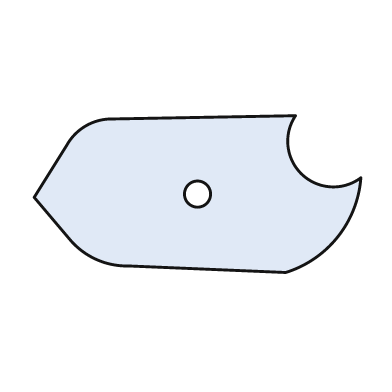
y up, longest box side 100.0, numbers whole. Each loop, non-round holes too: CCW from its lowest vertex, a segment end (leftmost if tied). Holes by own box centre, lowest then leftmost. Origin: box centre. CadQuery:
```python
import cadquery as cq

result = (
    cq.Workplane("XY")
    .moveTo(27.0, -24.0)
    .threePointArc((43.0, -13.0), (50.0, 5.0))
    .threePointArc((32.0, 6.0), (30.0, 24.0))
    .lineTo(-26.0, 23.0)
    .threePointArc((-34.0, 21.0), (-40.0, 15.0))
    .lineTo(-50.0, -1.0)
    .lineTo(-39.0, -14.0)
    .threePointArc((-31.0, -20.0), (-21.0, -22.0))
    .close()
    .moveTo(0.0, 0.0)
    .circle(4.0)
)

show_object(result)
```